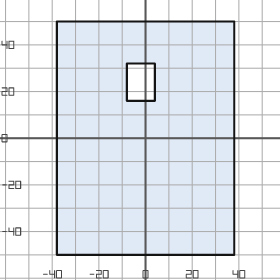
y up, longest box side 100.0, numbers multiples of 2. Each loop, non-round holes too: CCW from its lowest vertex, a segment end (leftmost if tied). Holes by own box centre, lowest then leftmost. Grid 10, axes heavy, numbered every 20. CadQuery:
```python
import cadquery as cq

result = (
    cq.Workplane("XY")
    .moveTo(-38.0, -50.0)
    .lineTo(38.0, -50.0)
    .lineTo(38.0, 50.0)
    .lineTo(-38.0, 50.0)
    .close()
    .moveTo(-8.0, 16.0)
    .lineTo(4.0, 16.0)
    .lineTo(4.0, 32.0)
    .lineTo(-8.0, 32.0)
    .close()
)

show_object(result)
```